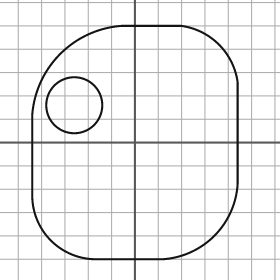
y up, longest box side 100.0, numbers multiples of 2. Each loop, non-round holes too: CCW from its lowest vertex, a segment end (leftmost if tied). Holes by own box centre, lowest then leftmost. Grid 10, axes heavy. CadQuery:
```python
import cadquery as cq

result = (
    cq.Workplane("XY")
    .moveTo(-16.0, -50.0)
    .lineTo(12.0, -50.0)
    .threePointArc((34.0, -40.0), (44.0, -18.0))
    .lineTo(44.0, 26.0)
    .threePointArc((36.0, 42.0), (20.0, 50.0))
    .lineTo(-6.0, 50.0)
    .threePointArc((-32.0, 38.0), (-44.0, 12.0))
    .lineTo(-44.0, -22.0)
    .threePointArc((-36.0, -42.0), (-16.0, -50.0))
    .close()
    .moveTo(-26.0, 16.0)
    .circle(12.0)
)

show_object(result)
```